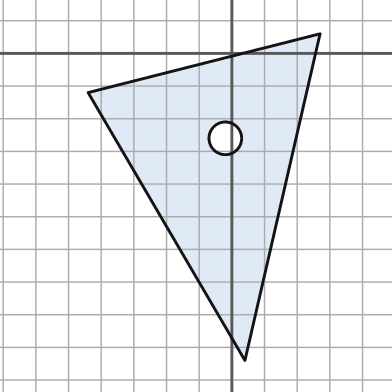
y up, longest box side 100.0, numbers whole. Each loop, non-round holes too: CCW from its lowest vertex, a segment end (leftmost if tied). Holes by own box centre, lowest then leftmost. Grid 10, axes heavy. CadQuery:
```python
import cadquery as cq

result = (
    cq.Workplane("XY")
    .moveTo(4.0, -94.0)
    .lineTo(27.0, 6.0)
    .lineTo(-44.0, -12.0)
    .close()
    .moveTo(-2.0, -26.0)
    .circle(5.0)
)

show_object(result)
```